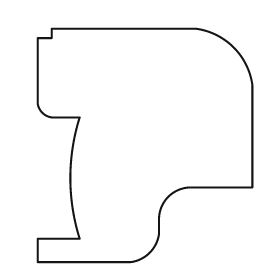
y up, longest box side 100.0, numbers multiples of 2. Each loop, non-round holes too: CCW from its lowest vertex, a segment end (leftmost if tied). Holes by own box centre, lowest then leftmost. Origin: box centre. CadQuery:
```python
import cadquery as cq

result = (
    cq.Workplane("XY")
    .moveTo(-46.0, -50.0)
    .lineTo(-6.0, -50.0)
    .threePointArc((2.0, -46.0), (6.0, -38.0))
    .lineTo(6.0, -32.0)
    .threePointArc((10.0, -22.0), (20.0, -18.0))
    .lineTo(46.0, -18.0)
    .lineTo(46.0, 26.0)
    .threePointArc((38.0, 42.0), (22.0, 50.0))
    .lineTo(-40.0, 50.0)
    .lineTo(-40.0, 46.0)
    .lineTo(-46.0, 46.0)
    .lineTo(-46.0, 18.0)
    .threePointArc((-44.0, 14.0), (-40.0, 12.0))
    .lineTo(-28.0, 12.0)
    .threePointArc((-32.0, -14.0), (-28.0, -40.0))
    .lineTo(-46.0, -40.0)
    .close()
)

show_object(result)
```